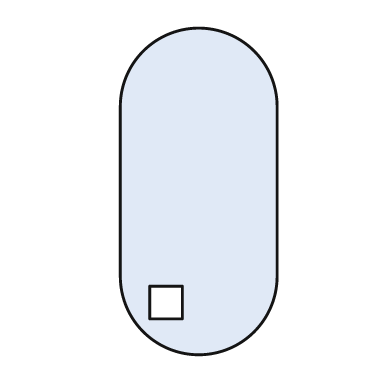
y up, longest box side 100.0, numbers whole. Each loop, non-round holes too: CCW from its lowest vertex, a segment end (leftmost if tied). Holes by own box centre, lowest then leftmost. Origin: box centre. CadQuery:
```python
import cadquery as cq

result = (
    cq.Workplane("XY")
    .moveTo(-24.0, -26.0)
    .threePointArc((0.0, -50.0), (24.0, -26.0))
    .lineTo(24.0, 26.0)
    .threePointArc((0.0, 50.0), (-24.0, 26.0))
    .close()
    .moveTo(-15.0, -39.0)
    .lineTo(-5.0, -39.0)
    .lineTo(-5.0, -29.0)
    .lineTo(-15.0, -29.0)
    .close()
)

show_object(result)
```